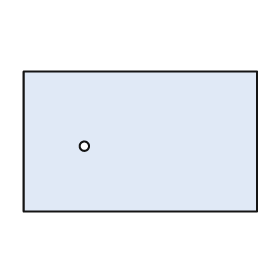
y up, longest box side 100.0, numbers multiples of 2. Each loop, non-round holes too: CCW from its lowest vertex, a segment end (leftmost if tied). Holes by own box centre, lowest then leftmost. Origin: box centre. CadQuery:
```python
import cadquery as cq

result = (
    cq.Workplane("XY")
    .moveTo(-50.0, -30.0)
    .lineTo(50.0, -30.0)
    .lineTo(50.0, 30.0)
    .lineTo(-50.0, 30.0)
    .close()
    .moveTo(-24.0, -2.0)
    .circle(2.0)
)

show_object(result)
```